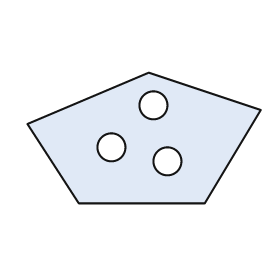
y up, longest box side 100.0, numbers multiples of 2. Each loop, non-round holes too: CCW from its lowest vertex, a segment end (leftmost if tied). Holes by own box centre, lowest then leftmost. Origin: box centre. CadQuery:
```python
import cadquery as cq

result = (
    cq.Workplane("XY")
    .moveTo(-28.0, -28.0)
    .lineTo(26.0, -28.0)
    .lineTo(50.0, 12.0)
    .lineTo(2.0, 28.0)
    .lineTo(-50.0, 6.0)
    .close()
    .moveTo(10.0, -10.0)
    .circle(6.0)
    .moveTo(-14.0, -4.0)
    .circle(6.0)
    .moveTo(4.0, 14.0)
    .circle(6.0)
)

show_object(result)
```